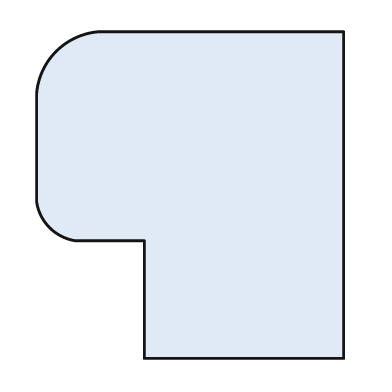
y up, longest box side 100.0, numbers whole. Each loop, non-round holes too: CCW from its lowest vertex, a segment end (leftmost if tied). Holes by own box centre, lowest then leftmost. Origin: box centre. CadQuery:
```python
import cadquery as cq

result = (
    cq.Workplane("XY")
    .moveTo(-14.0, -50.0)
    .lineTo(47.0, -50.0)
    .lineTo(47.0, 50.0)
    .lineTo(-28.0, 50.0)
    .threePointArc((-41.0, 44.0), (-47.0, 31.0))
    .lineTo(-47.0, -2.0)
    .threePointArc((-43.0, -10.0), (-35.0, -14.0))
    .lineTo(-14.0, -14.0)
    .close()
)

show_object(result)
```